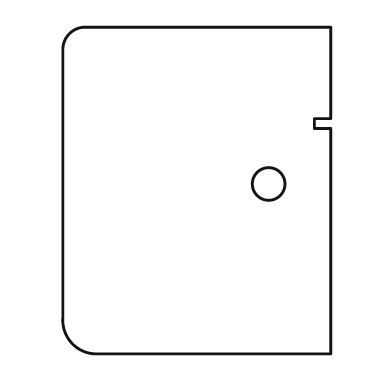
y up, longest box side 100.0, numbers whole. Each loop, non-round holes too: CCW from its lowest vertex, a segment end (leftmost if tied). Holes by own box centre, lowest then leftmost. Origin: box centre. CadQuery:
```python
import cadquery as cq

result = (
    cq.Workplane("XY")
    .moveTo(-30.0, -50.0)
    .lineTo(41.0, -50.0)
    .lineTo(41.0, 19.0)
    .lineTo(36.0, 19.0)
    .lineTo(36.0, 22.0)
    .lineTo(41.0, 22.0)
    .lineTo(41.0, 50.0)
    .lineTo(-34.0, 50.0)
    .threePointArc((-39.0, 48.0), (-41.0, 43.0))
    .lineTo(-41.0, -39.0)
    .threePointArc((-38.0, -47.0), (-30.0, -50.0))
    .close()
    .moveTo(22.0, 2.0)
    .circle(5.0)
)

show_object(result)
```